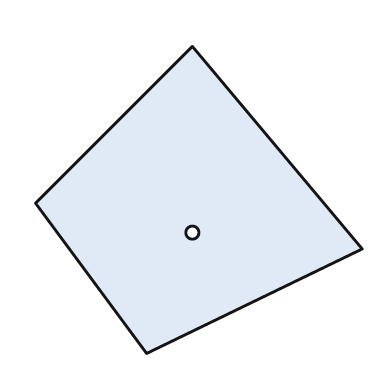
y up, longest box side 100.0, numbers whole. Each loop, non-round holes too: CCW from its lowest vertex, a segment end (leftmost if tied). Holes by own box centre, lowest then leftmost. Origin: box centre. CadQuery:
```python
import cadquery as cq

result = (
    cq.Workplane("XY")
    .moveTo(-16.0, -47.0)
    .lineTo(50.0, -15.0)
    .lineTo(-2.0, 47.0)
    .lineTo(-50.0, -1.0)
    .close()
    .moveTo(-2.0, -10.0)
    .circle(2.0)
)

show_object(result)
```